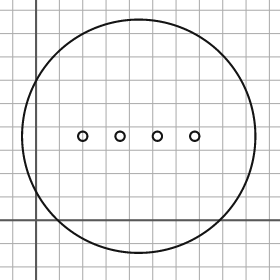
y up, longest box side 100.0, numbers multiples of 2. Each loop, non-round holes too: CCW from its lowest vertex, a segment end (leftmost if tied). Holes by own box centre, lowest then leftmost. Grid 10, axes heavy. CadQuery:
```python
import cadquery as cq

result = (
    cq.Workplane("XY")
    .moveTo(44.0, 36.0)
    .circle(50.0)
    .moveTo(20.0, 36.0)
    .circle(2.0)
    .moveTo(36.0, 36.0)
    .circle(2.0)
    .moveTo(52.0, 36.0)
    .circle(2.0)
    .moveTo(68.0, 36.0)
    .circle(2.0)
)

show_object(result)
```